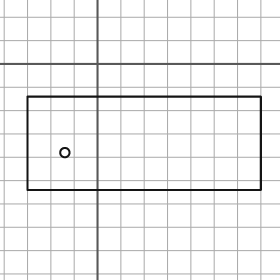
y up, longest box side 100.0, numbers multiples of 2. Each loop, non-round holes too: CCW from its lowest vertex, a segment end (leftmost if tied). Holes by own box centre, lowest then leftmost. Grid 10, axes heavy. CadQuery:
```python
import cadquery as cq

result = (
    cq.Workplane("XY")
    .moveTo(-30.0, -54.0)
    .lineTo(70.0, -54.0)
    .lineTo(70.0, -14.0)
    .lineTo(-30.0, -14.0)
    .close()
    .moveTo(-14.0, -38.0)
    .circle(2.0)
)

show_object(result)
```